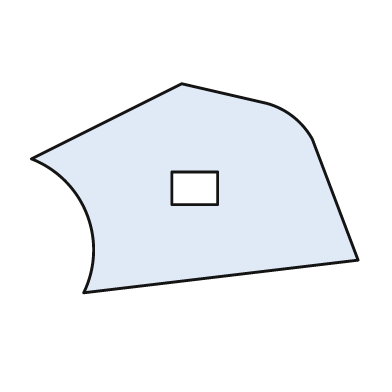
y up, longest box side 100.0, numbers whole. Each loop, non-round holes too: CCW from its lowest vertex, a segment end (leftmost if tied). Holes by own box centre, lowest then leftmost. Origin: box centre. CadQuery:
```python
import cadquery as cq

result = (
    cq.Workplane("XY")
    .moveTo(-34.0, -32.0)
    .lineTo(50.0, -22.0)
    .lineTo(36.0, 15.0)
    .threePointArc((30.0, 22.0), (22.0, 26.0))
    .lineTo(-4.0, 32.0)
    .lineTo(-50.0, 9.0)
    .threePointArc((-33.0, -8.0), (-34.0, -32.0))
    .close()
    .moveTo(-7.0, -5.0)
    .lineTo(7.0, -5.0)
    .lineTo(7.0, 5.0)
    .lineTo(-7.0, 5.0)
    .close()
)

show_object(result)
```